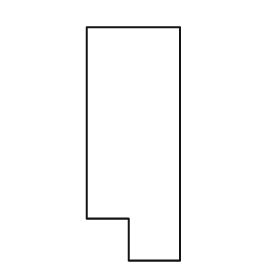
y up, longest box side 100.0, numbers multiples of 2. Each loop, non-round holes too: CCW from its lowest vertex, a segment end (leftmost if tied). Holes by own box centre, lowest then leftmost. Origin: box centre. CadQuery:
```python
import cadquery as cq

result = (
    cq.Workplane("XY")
    .moveTo(-2.0, -50.0)
    .lineTo(20.0, -50.0)
    .lineTo(20.0, 50.0)
    .lineTo(-20.0, 50.0)
    .lineTo(-20.0, -32.0)
    .lineTo(-2.0, -32.0)
    .close()
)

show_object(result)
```